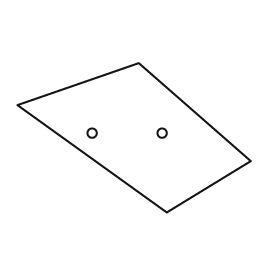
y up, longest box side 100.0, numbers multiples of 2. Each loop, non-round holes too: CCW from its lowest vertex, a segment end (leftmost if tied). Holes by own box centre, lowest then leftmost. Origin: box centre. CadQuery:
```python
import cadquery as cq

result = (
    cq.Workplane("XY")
    .moveTo(14.0, -32.0)
    .lineTo(50.0, -10.0)
    .lineTo(2.0, 32.0)
    .lineTo(-50.0, 14.0)
    .close()
    .moveTo(-18.0, 2.0)
    .circle(2.0)
    .moveTo(12.0, 2.0)
    .circle(2.0)
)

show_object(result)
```